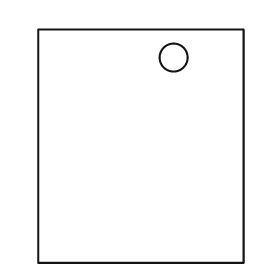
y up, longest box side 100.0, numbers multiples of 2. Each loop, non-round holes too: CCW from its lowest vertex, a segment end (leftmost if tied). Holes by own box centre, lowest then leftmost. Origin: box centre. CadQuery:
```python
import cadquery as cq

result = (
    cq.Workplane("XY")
    .moveTo(-44.0, -50.0)
    .lineTo(44.0, -50.0)
    .lineTo(44.0, 50.0)
    .lineTo(-44.0, 50.0)
    .close()
    .moveTo(14.0, 38.0)
    .circle(6.0)
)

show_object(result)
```